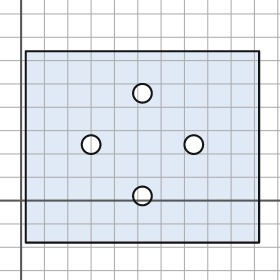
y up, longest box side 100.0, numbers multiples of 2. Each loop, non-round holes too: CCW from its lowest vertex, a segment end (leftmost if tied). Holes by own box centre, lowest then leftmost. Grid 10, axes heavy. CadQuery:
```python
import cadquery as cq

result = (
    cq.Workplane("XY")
    .moveTo(2.0, -18.0)
    .lineTo(102.0, -18.0)
    .lineTo(102.0, 64.0)
    .lineTo(2.0, 64.0)
    .close()
    .moveTo(52.0, 2.0)
    .circle(4.0)
    .moveTo(30.0, 24.0)
    .circle(4.0)
    .moveTo(74.0, 24.0)
    .circle(4.0)
    .moveTo(52.0, 46.0)
    .circle(4.0)
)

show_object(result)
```